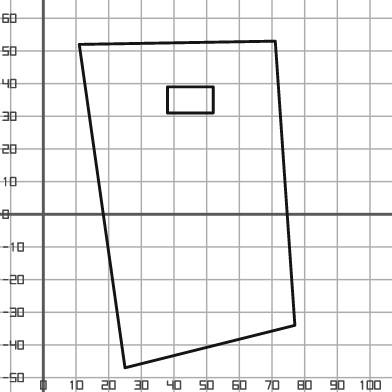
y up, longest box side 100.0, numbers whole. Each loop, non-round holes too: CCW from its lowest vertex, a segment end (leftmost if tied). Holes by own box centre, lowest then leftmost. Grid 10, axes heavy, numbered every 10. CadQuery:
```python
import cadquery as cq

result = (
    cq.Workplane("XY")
    .moveTo(25.0, -47.0)
    .lineTo(77.0, -34.0)
    .lineTo(71.0, 53.0)
    .lineTo(11.0, 52.0)
    .close()
    .moveTo(38.0, 31.0)
    .lineTo(52.0, 31.0)
    .lineTo(52.0, 39.0)
    .lineTo(38.0, 39.0)
    .close()
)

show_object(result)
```